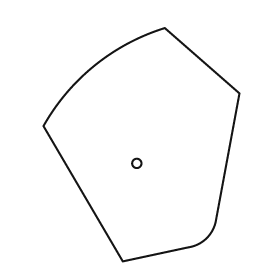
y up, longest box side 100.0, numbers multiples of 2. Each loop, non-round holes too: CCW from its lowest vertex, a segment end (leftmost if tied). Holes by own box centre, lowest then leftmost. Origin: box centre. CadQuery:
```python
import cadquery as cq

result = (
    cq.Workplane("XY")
    .moveTo(-8.0, -50.0)
    .lineTo(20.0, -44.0)
    .threePointArc((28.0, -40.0), (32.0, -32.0))
    .lineTo(42.0, 22.0)
    .lineTo(10.0, 50.0)
    .threePointArc((-20.0, 34.0), (-42.0, 8.0))
    .close()
    .moveTo(-2.0, -8.0)
    .circle(2.0)
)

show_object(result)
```